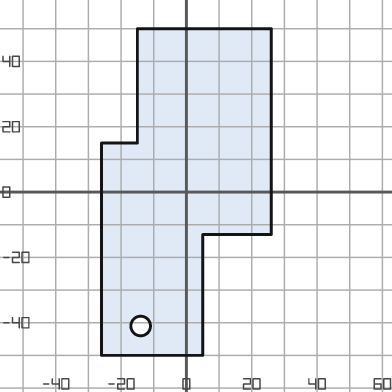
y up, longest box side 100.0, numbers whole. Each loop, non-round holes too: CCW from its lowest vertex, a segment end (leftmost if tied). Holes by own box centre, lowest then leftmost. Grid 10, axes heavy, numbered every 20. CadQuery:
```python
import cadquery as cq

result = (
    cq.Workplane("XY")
    .moveTo(-26.0, -50.0)
    .lineTo(5.0, -50.0)
    .lineTo(5.0, -13.0)
    .lineTo(26.0, -13.0)
    .lineTo(26.0, 50.0)
    .lineTo(-15.0, 50.0)
    .lineTo(-15.0, 15.0)
    .lineTo(-26.0, 15.0)
    .close()
    .moveTo(-14.0, -41.0)
    .circle(3.0)
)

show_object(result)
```